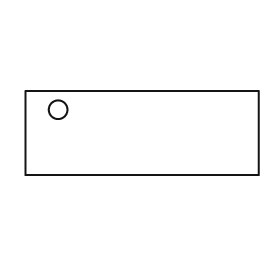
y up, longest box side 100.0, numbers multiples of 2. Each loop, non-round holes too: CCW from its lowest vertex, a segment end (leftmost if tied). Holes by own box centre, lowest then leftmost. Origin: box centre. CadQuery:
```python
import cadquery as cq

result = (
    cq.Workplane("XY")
    .moveTo(-50.0, -18.0)
    .lineTo(50.0, -18.0)
    .lineTo(50.0, 18.0)
    .lineTo(-50.0, 18.0)
    .close()
    .moveTo(-36.0, 10.0)
    .circle(4.0)
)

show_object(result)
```